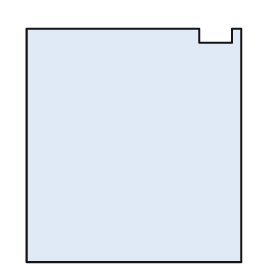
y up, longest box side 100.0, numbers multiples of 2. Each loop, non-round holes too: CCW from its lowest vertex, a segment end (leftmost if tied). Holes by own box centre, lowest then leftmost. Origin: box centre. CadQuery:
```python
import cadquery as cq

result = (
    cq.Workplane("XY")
    .moveTo(-46.0, -50.0)
    .lineTo(46.0, -50.0)
    .lineTo(46.0, 50.0)
    .lineTo(42.0, 50.0)
    .lineTo(42.0, 44.0)
    .lineTo(28.0, 44.0)
    .lineTo(28.0, 50.0)
    .lineTo(-46.0, 50.0)
    .close()
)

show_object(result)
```